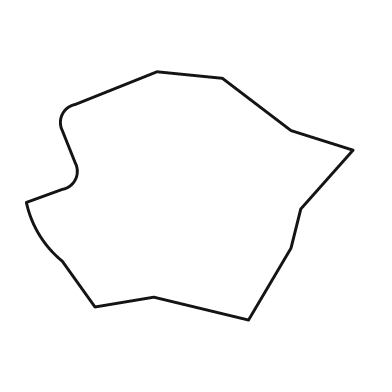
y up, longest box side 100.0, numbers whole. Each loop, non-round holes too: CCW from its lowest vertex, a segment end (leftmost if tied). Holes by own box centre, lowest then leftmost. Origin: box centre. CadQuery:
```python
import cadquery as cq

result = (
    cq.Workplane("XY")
    .moveTo(18.0, -38.0)
    .lineTo(31.0, -16.0)
    .lineTo(34.0, -4.0)
    .lineTo(50.0, 14.0)
    .lineTo(31.0, 20.0)
    .lineTo(10.0, 36.0)
    .lineTo(-10.0, 38.0)
    .lineTo(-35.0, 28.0)
    .threePointArc((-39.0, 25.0), (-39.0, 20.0))
    .lineTo(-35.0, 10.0)
    .threePointArc((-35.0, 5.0), (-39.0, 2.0))
    .lineTo(-50.0, -2.0)
    .threePointArc((-46.0, -12.0), (-39.0, -20.0))
    .lineTo(-29.0, -34.0)
    .lineTo(-11.0, -31.0)
    .close()
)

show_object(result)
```